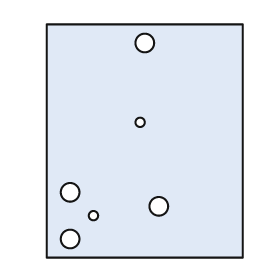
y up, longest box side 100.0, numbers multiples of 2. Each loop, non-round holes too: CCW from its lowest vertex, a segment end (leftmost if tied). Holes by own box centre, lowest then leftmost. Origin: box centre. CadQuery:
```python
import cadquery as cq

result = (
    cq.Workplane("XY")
    .moveTo(-42.0, -50.0)
    .lineTo(42.0, -50.0)
    .lineTo(42.0, 50.0)
    .lineTo(-42.0, 50.0)
    .close()
    .moveTo(-32.0, -42.0)
    .circle(4.0)
    .moveTo(-22.0, -32.0)
    .circle(2.0)
    .moveTo(6.0, -28.0)
    .circle(4.0)
    .moveTo(-32.0, -22.0)
    .circle(4.0)
    .moveTo(-2.0, 8.0)
    .circle(2.0)
    .moveTo(0.0, 42.0)
    .circle(4.0)
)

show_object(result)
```